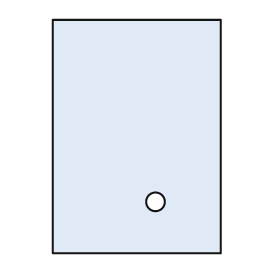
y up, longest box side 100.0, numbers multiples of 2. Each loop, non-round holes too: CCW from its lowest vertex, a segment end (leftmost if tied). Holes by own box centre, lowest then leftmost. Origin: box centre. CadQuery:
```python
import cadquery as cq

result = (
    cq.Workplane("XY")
    .moveTo(-36.0, -50.0)
    .lineTo(36.0, -50.0)
    .lineTo(36.0, 50.0)
    .lineTo(-36.0, 50.0)
    .close()
    .moveTo(8.0, -28.0)
    .circle(4.0)
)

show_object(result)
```